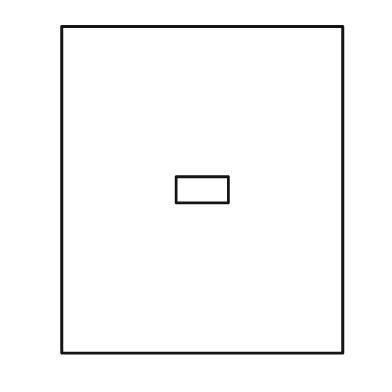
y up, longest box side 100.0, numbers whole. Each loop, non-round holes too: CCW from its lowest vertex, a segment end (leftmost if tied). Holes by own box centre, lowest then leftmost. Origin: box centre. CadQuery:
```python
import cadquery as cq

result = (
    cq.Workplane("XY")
    .moveTo(-43.0, -50.0)
    .lineTo(43.0, -50.0)
    .lineTo(43.0, 50.0)
    .lineTo(-43.0, 50.0)
    .close()
    .moveTo(-8.0, -4.0)
    .lineTo(8.0, -4.0)
    .lineTo(8.0, 4.0)
    .lineTo(-8.0, 4.0)
    .close()
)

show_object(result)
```